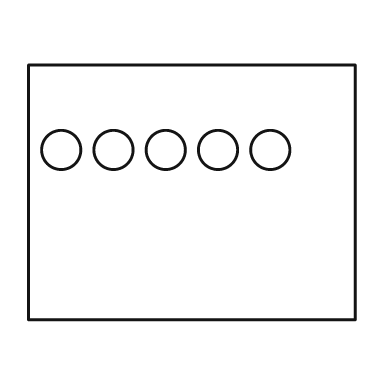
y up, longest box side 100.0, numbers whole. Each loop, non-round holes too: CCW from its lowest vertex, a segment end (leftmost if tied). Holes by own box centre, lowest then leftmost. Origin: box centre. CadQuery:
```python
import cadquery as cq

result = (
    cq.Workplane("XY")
    .moveTo(-50.0, -39.0)
    .lineTo(50.0, -39.0)
    .lineTo(50.0, 39.0)
    .lineTo(-50.0, 39.0)
    .close()
    .moveTo(-40.0, 13.0)
    .circle(6.0)
    .moveTo(-24.0, 13.0)
    .circle(6.0)
    .moveTo(-8.0, 13.0)
    .circle(6.0)
    .moveTo(8.0, 13.0)
    .circle(6.0)
    .moveTo(24.0, 13.0)
    .circle(6.0)
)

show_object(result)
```